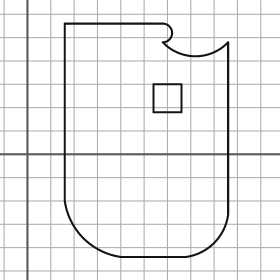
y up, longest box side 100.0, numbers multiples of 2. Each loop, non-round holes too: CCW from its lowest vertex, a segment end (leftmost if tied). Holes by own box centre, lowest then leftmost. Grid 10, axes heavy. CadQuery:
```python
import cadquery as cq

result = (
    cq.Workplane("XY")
    .moveTo(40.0, -44.0)
    .lineTo(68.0, -44.0)
    .threePointArc((80.0, -38.0), (86.0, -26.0))
    .lineTo(86.0, 48.0)
    .threePointArc((72.0, 42.0), (58.0, 48.0))
    .threePointArc((62.0, 52.0), (58.0, 56.0))
    .lineTo(16.0, 56.0)
    .lineTo(16.0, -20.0)
    .threePointArc((24.0, -36.0), (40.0, -44.0))
    .close()
    .moveTo(54.0, 18.0)
    .lineTo(66.0, 18.0)
    .lineTo(66.0, 30.0)
    .lineTo(54.0, 30.0)
    .close()
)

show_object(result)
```